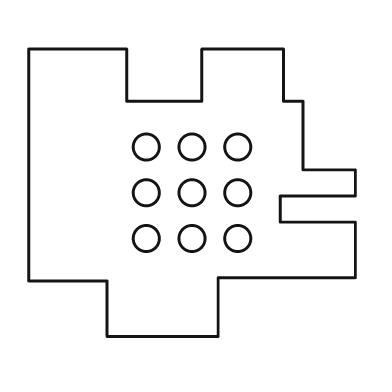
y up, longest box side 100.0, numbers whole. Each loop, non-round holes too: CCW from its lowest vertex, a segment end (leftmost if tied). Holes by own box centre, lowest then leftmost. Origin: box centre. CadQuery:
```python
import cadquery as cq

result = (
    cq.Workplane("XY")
    .moveTo(-26.0, -44.0)
    .lineTo(8.0, -44.0)
    .lineTo(8.0, -26.0)
    .lineTo(50.0, -26.0)
    .lineTo(50.0, -9.0)
    .lineTo(27.0, -9.0)
    .lineTo(27.0, -1.0)
    .lineTo(50.0, -1.0)
    .lineTo(50.0, 7.0)
    .lineTo(34.0, 7.0)
    .lineTo(34.0, 28.0)
    .lineTo(28.0, 28.0)
    .lineTo(28.0, 44.0)
    .lineTo(3.0, 44.0)
    .lineTo(3.0, 28.0)
    .lineTo(-20.0, 28.0)
    .lineTo(-20.0, 44.0)
    .lineTo(-50.0, 44.0)
    .lineTo(-50.0, -27.0)
    .lineTo(-26.0, -27.0)
    .close()
    .moveTo(-14.0, -14.0)
    .circle(4.0)
    .moveTo(0.0, -14.0)
    .circle(4.0)
    .moveTo(14.0, -14.0)
    .circle(4.0)
    .moveTo(-14.0, 0.0)
    .circle(4.0)
    .moveTo(0.0, 0.0)
    .circle(4.0)
    .moveTo(14.0, 0.0)
    .circle(4.0)
    .moveTo(-14.0, 14.0)
    .circle(4.0)
    .moveTo(0.0, 14.0)
    .circle(4.0)
    .moveTo(14.0, 14.0)
    .circle(4.0)
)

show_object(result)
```